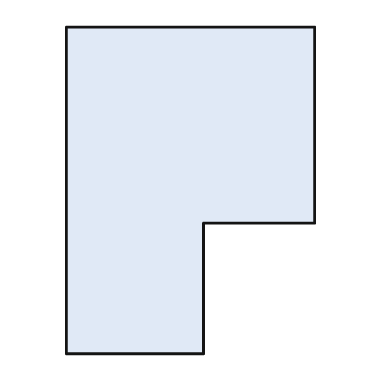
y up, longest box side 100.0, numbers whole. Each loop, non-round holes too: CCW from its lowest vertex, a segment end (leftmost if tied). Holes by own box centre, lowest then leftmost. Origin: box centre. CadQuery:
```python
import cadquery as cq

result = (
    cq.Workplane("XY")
    .moveTo(-38.0, -50.0)
    .lineTo(4.0, -50.0)
    .lineTo(4.0, -10.0)
    .lineTo(38.0, -10.0)
    .lineTo(38.0, 50.0)
    .lineTo(-38.0, 50.0)
    .close()
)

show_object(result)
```